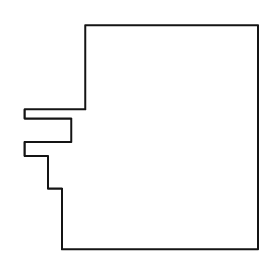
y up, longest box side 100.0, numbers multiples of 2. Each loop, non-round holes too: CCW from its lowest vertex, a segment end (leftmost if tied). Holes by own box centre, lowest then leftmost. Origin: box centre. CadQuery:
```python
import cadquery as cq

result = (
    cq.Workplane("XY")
    .moveTo(-34.0, -48.0)
    .lineTo(50.0, -48.0)
    .lineTo(50.0, 48.0)
    .lineTo(-24.0, 48.0)
    .lineTo(-24.0, 12.0)
    .lineTo(-50.0, 12.0)
    .lineTo(-50.0, 8.0)
    .lineTo(-30.0, 8.0)
    .lineTo(-30.0, -2.0)
    .lineTo(-50.0, -2.0)
    .lineTo(-50.0, -8.0)
    .lineTo(-40.0, -8.0)
    .lineTo(-40.0, -22.0)
    .lineTo(-34.0, -22.0)
    .close()
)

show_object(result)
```